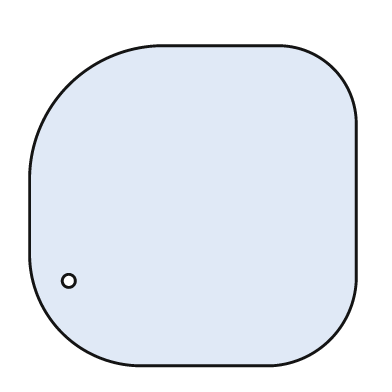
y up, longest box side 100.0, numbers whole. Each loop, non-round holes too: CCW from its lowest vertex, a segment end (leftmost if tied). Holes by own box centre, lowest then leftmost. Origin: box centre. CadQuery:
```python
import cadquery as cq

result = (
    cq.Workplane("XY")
    .moveTo(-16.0, -49.0)
    .lineTo(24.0, -49.0)
    .threePointArc((42.0, -41.0), (50.0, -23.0))
    .lineTo(50.0, 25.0)
    .threePointArc((43.0, 42.0), (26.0, 49.0))
    .lineTo(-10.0, 49.0)
    .threePointArc((-38.0, 37.0), (-50.0, 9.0))
    .lineTo(-50.0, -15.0)
    .threePointArc((-40.0, -39.0), (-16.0, -49.0))
    .close()
    .moveTo(-38.0, -23.0)
    .circle(2.0)
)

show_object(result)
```